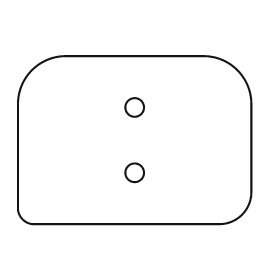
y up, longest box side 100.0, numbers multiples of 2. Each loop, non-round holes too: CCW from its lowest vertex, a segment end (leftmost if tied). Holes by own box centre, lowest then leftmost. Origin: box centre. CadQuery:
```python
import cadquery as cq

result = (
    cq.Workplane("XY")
    .moveTo(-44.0, -36.0)
    .lineTo(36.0, -36.0)
    .threePointArc((46.0, -32.0), (50.0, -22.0))
    .lineTo(50.0, 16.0)
    .threePointArc((44.0, 30.0), (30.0, 36.0))
    .lineTo(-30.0, 36.0)
    .threePointArc((-44.0, 30.0), (-50.0, 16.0))
    .lineTo(-50.0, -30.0)
    .threePointArc((-48.0, -34.0), (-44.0, -36.0))
    .close()
    .moveTo(0.0, -14.0)
    .circle(4.0)
    .moveTo(0.0, 14.0)
    .circle(4.0)
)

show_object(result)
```